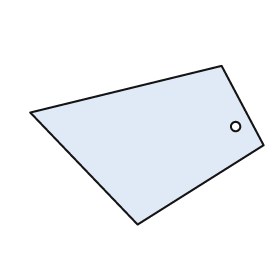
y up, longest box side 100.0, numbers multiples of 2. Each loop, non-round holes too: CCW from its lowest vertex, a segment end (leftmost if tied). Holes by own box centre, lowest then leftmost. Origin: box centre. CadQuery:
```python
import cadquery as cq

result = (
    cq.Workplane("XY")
    .moveTo(-4.0, -34.0)
    .lineTo(50.0, 0.0)
    .lineTo(32.0, 34.0)
    .lineTo(-50.0, 14.0)
    .close()
    .moveTo(38.0, 8.0)
    .circle(2.0)
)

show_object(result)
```